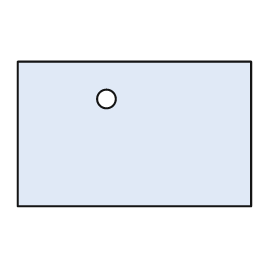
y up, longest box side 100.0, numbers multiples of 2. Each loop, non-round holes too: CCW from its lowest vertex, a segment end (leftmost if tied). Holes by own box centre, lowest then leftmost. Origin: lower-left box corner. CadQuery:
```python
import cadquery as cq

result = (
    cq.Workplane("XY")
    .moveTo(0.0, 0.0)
    .lineTo(100.0, 0.0)
    .lineTo(100.0, 62.0)
    .lineTo(0.0, 62.0)
    .close()
    .moveTo(38.0, 46.0)
    .circle(4.0)
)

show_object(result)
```